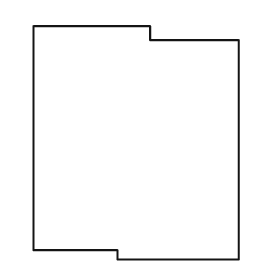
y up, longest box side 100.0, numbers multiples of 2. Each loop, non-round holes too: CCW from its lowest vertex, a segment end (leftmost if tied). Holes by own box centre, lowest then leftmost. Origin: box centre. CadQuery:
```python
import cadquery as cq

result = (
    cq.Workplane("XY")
    .moveTo(-8.0, -50.0)
    .lineTo(44.0, -50.0)
    .lineTo(44.0, 44.0)
    .lineTo(6.0, 44.0)
    .lineTo(6.0, 50.0)
    .lineTo(-44.0, 50.0)
    .lineTo(-44.0, -46.0)
    .lineTo(-8.0, -46.0)
    .close()
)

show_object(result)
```